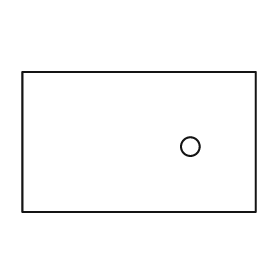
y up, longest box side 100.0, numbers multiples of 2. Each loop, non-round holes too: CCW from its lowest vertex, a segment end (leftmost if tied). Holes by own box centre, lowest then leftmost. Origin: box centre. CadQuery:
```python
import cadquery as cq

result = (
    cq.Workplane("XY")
    .moveTo(-50.0, -30.0)
    .lineTo(50.0, -30.0)
    .lineTo(50.0, 30.0)
    .lineTo(-50.0, 30.0)
    .close()
    .moveTo(22.0, -2.0)
    .circle(4.0)
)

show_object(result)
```